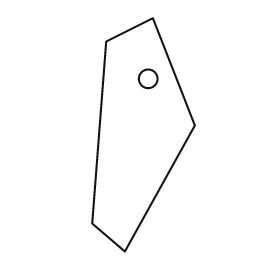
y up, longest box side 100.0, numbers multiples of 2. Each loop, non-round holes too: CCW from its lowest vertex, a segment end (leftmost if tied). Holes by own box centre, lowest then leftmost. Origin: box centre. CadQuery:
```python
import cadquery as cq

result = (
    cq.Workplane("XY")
    .moveTo(-8.0, -50.0)
    .lineTo(22.0, 4.0)
    .lineTo(4.0, 50.0)
    .lineTo(-16.0, 40.0)
    .lineTo(-22.0, -38.0)
    .close()
    .moveTo(2.0, 24.0)
    .circle(4.0)
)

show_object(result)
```